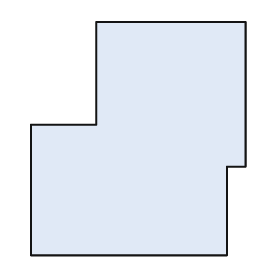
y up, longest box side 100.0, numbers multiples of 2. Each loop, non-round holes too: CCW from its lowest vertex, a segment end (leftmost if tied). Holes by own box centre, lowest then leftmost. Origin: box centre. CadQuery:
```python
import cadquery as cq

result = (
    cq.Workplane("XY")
    .moveTo(-46.0, -50.0)
    .lineTo(38.0, -50.0)
    .lineTo(38.0, -12.0)
    .lineTo(46.0, -12.0)
    .lineTo(46.0, 50.0)
    .lineTo(-18.0, 50.0)
    .lineTo(-18.0, 6.0)
    .lineTo(-46.0, 6.0)
    .close()
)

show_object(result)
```